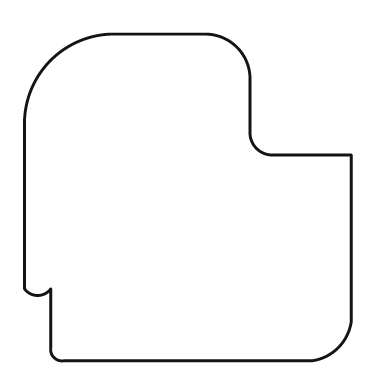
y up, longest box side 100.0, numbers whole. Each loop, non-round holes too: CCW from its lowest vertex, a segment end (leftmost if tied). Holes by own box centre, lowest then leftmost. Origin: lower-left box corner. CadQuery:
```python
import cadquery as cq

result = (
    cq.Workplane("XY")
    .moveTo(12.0, 0.0)
    .lineTo(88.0, 0.0)
    .threePointArc((96.0, 4.0), (100.0, 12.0))
    .lineTo(100.0, 63.0)
    .lineTo(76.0, 63.0)
    .threePointArc((71.0, 65.0), (69.0, 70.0))
    .lineTo(69.0, 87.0)
    .threePointArc((65.0, 96.0), (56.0, 100.0))
    .lineTo(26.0, 100.0)
    .threePointArc((8.0, 92.0), (0.0, 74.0))
    .lineTo(0.0, 22.0)
    .threePointArc((4.0, 20.0), (8.0, 22.0))
    .lineTo(8.0, 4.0)
    .threePointArc((9.0, 1.0), (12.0, 0.0))
    .close()
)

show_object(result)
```